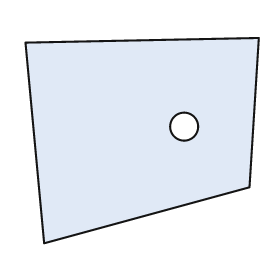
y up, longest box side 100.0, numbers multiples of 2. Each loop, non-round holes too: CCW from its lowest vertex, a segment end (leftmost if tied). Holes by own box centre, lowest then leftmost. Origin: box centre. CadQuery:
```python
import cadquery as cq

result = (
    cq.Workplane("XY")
    .moveTo(-42.0, -44.0)
    .lineTo(46.0, -20.0)
    .lineTo(50.0, 44.0)
    .lineTo(-50.0, 42.0)
    .close()
    .moveTo(18.0, 6.0)
    .circle(6.0)
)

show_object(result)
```